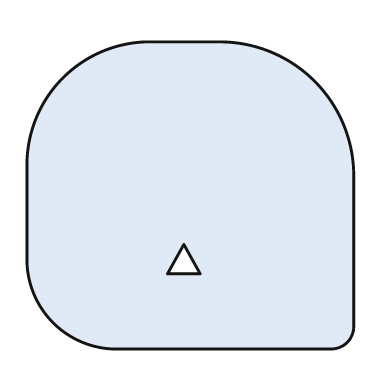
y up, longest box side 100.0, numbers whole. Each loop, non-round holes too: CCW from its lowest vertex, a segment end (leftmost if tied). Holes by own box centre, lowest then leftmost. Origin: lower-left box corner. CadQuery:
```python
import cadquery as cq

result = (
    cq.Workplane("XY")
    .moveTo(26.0, 0.0)
    .lineTo(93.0, 0.0)
    .threePointArc((98.0, 2.0), (100.0, 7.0))
    .lineTo(100.0, 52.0)
    .threePointArc((88.0, 82.0), (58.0, 94.0))
    .lineTo(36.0, 94.0)
    .threePointArc((11.0, 83.0), (0.0, 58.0))
    .lineTo(0.0, 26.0)
    .threePointArc((8.0, 8.0), (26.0, 0.0))
    .close()
    .moveTo(43.0, 23.0)
    .lineTo(53.0, 23.0)
    .lineTo(48.0, 32.0)
    .close()
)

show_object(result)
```